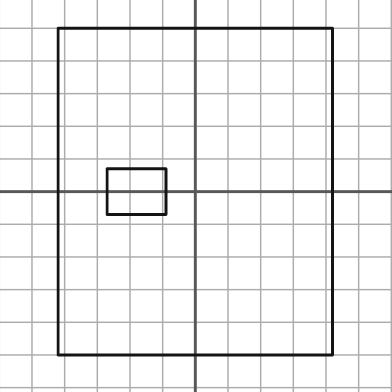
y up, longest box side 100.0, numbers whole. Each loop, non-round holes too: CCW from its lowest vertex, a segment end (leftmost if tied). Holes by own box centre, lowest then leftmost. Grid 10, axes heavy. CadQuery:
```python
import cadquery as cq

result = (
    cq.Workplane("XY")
    .moveTo(-42.0, -50.0)
    .lineTo(42.0, -50.0)
    .lineTo(42.0, 50.0)
    .lineTo(-42.0, 50.0)
    .close()
    .moveTo(-27.0, -7.0)
    .lineTo(-9.0, -7.0)
    .lineTo(-9.0, 7.0)
    .lineTo(-27.0, 7.0)
    .close()
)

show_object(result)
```